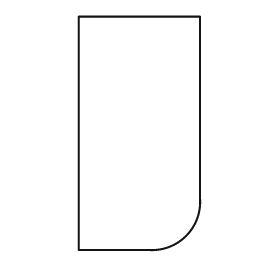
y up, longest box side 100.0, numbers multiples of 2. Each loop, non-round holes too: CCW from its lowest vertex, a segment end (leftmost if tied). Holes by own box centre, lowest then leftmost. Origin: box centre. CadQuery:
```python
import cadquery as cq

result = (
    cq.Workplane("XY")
    .moveTo(-26.0, -50.0)
    .lineTo(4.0, -50.0)
    .threePointArc((20.0, -44.0), (26.0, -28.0))
    .lineTo(26.0, 50.0)
    .lineTo(-26.0, 50.0)
    .close()
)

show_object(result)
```